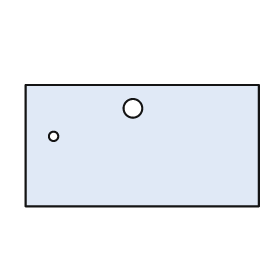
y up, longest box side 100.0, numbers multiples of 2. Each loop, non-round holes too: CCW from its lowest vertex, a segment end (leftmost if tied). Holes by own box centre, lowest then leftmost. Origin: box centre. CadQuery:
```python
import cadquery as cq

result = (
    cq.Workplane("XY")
    .moveTo(-50.0, -26.0)
    .lineTo(50.0, -26.0)
    .lineTo(50.0, 26.0)
    .lineTo(-50.0, 26.0)
    .close()
    .moveTo(-38.0, 4.0)
    .circle(2.0)
    .moveTo(-4.0, 16.0)
    .circle(4.0)
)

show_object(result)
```